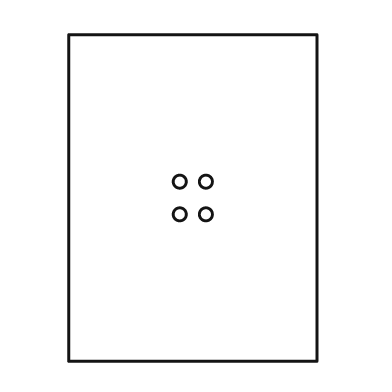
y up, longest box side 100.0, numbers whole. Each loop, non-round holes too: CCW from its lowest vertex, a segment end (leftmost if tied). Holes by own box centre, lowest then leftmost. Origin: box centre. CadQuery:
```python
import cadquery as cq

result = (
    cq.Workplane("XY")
    .moveTo(-38.0, -50.0)
    .lineTo(38.0, -50.0)
    .lineTo(38.0, 50.0)
    .lineTo(-38.0, 50.0)
    .close()
    .moveTo(-4.0, -5.0)
    .circle(2.0)
    .moveTo(4.0, -5.0)
    .circle(2.0)
    .moveTo(-4.0, 5.0)
    .circle(2.0)
    .moveTo(4.0, 5.0)
    .circle(2.0)
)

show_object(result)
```